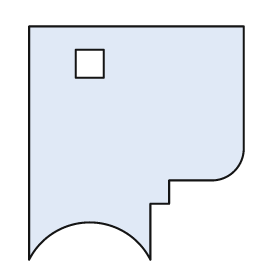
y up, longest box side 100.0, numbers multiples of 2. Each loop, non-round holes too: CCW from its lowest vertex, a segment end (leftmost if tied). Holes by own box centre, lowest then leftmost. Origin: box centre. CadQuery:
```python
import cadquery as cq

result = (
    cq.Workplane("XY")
    .moveTo(-46.0, -50.0)
    .threePointArc((-20.0, -34.0), (6.0, -50.0))
    .lineTo(6.0, -26.0)
    .lineTo(14.0, -26.0)
    .lineTo(14.0, -16.0)
    .lineTo(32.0, -16.0)
    .threePointArc((42.0, -12.0), (46.0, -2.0))
    .lineTo(46.0, 50.0)
    .lineTo(-46.0, 50.0)
    .close()
    .moveTo(-26.0, 28.0)
    .lineTo(-14.0, 28.0)
    .lineTo(-14.0, 40.0)
    .lineTo(-26.0, 40.0)
    .close()
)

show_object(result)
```